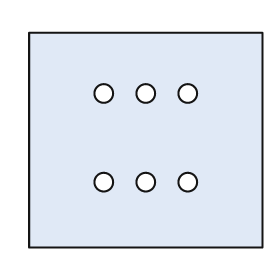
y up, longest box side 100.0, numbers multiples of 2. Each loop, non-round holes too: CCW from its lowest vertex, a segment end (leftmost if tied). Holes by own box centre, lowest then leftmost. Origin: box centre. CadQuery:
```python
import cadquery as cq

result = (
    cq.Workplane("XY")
    .moveTo(-50.0, -46.0)
    .lineTo(50.0, -46.0)
    .lineTo(50.0, 46.0)
    .lineTo(-50.0, 46.0)
    .close()
    .moveTo(-18.0, -18.0)
    .circle(4.0)
    .moveTo(0.0, -18.0)
    .circle(4.0)
    .moveTo(18.0, -18.0)
    .circle(4.0)
    .moveTo(-18.0, 20.0)
    .circle(4.0)
    .moveTo(0.0, 20.0)
    .circle(4.0)
    .moveTo(18.0, 20.0)
    .circle(4.0)
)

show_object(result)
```